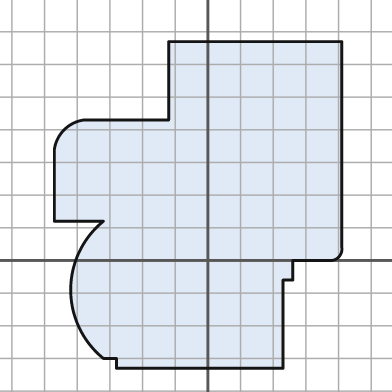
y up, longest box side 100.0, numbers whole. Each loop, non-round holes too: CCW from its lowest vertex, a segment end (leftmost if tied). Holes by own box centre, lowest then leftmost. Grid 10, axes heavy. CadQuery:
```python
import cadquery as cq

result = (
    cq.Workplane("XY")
    .moveTo(-28.0, -33.0)
    .lineTo(23.0, -33.0)
    .lineTo(23.0, -6.0)
    .lineTo(26.0, -6.0)
    .lineTo(26.0, 0.0)
    .lineTo(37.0, 0.0)
    .threePointArc((40.0, 1.0), (41.0, 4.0))
    .lineTo(41.0, 67.0)
    .lineTo(-12.0, 67.0)
    .lineTo(-12.0, 43.0)
    .lineTo(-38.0, 43.0)
    .threePointArc((-44.0, 40.0), (-47.0, 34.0))
    .lineTo(-47.0, 12.0)
    .lineTo(-32.0, 12.0)
    .threePointArc((-42.0, -9.0), (-32.0, -30.0))
    .lineTo(-28.0, -30.0)
    .close()
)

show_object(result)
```